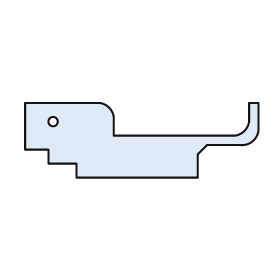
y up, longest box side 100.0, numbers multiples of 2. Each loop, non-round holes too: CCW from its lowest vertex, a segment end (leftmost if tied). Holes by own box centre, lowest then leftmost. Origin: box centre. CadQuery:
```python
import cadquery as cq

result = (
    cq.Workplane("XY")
    .moveTo(-28.0, -16.0)
    .lineTo(24.0, -16.0)
    .lineTo(24.0, -6.0)
    .lineTo(28.0, -2.0)
    .lineTo(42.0, -2.0)
    .threePointArc((48.0, 0.0), (50.0, 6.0))
    .lineTo(50.0, 16.0)
    .lineTo(46.0, 16.0)
    .lineTo(46.0, 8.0)
    .threePointArc((44.0, 4.0), (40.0, 2.0))
    .lineTo(-12.0, 2.0)
    .lineTo(-12.0, 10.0)
    .threePointArc((-14.0, 14.0), (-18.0, 16.0))
    .lineTo(-50.0, 16.0)
    .lineTo(-50.0, -4.0)
    .lineTo(-40.0, -4.0)
    .lineTo(-40.0, -10.0)
    .lineTo(-28.0, -10.0)
    .close()
    .moveTo(-38.0, 8.0)
    .circle(2.0)
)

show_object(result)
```